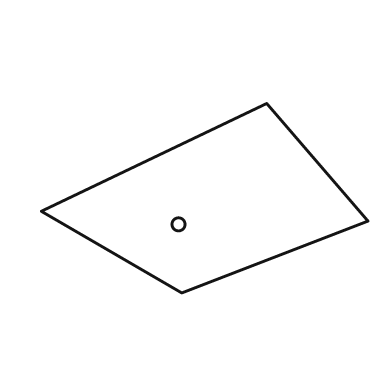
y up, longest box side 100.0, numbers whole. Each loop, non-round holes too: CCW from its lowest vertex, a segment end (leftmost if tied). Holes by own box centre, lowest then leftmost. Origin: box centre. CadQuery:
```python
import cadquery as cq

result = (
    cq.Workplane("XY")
    .moveTo(-7.0, -29.0)
    .lineTo(50.0, -7.0)
    .lineTo(19.0, 29.0)
    .lineTo(-50.0, -4.0)
    .close()
    .moveTo(-8.0, -8.0)
    .circle(2.0)
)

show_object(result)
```